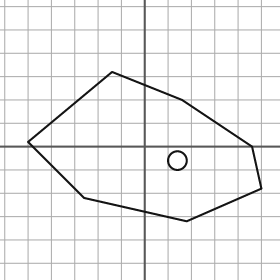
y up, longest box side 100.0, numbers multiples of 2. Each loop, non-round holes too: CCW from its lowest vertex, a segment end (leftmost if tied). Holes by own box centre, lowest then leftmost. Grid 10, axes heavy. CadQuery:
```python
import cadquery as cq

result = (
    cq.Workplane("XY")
    .moveTo(18.0, -32.0)
    .lineTo(50.0, -18.0)
    .lineTo(46.0, 0.0)
    .lineTo(16.0, 20.0)
    .lineTo(-14.0, 32.0)
    .lineTo(-50.0, 2.0)
    .lineTo(-26.0, -22.0)
    .close()
    .moveTo(14.0, -6.0)
    .circle(4.0)
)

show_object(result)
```